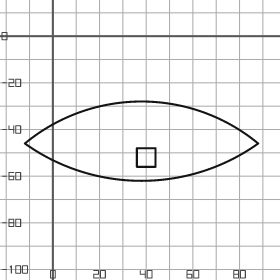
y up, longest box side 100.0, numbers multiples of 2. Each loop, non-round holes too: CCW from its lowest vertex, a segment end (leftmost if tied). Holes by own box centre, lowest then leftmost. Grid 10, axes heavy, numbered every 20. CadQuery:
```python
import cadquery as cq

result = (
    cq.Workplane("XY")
    .moveTo(-12.0, -46.0)
    .threePointArc((38.0, -62.0), (88.0, -46.0))
    .threePointArc((38.0, -28.0), (-12.0, -46.0))
    .close()
    .moveTo(36.0, -56.0)
    .lineTo(44.0, -56.0)
    .lineTo(44.0, -48.0)
    .lineTo(36.0, -48.0)
    .close()
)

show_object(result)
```